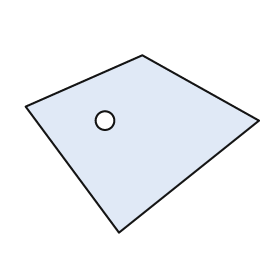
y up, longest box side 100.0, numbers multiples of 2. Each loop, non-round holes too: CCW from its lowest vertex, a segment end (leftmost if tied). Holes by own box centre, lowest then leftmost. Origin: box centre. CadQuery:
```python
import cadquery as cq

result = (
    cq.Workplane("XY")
    .moveTo(-10.0, -38.0)
    .lineTo(50.0, 10.0)
    .lineTo(0.0, 38.0)
    .lineTo(-50.0, 16.0)
    .close()
    .moveTo(-16.0, 10.0)
    .circle(4.0)
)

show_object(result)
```